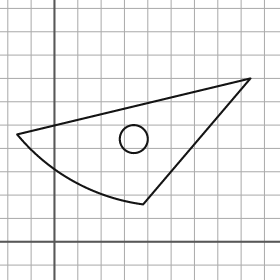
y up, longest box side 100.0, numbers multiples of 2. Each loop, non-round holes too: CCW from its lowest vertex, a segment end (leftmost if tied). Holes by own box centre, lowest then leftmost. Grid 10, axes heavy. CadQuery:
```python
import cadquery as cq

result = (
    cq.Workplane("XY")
    .moveTo(38.0, 16.0)
    .lineTo(84.0, 70.0)
    .lineTo(-16.0, 46.0)
    .threePointArc((8.0, 26.0), (38.0, 16.0))
    .close()
    .moveTo(34.0, 44.0)
    .circle(6.0)
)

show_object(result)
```